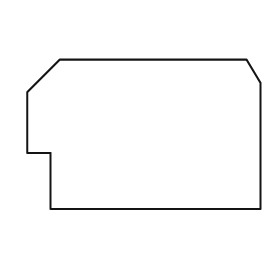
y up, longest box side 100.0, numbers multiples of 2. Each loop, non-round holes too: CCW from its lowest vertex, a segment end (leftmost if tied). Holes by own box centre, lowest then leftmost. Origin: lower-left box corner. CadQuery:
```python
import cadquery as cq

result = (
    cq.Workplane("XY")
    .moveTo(10.0, 0.0)
    .lineTo(100.0, 0.0)
    .lineTo(100.0, 54.0)
    .lineTo(94.0, 64.0)
    .lineTo(14.0, 64.0)
    .lineTo(0.0, 50.0)
    .lineTo(0.0, 24.0)
    .lineTo(10.0, 24.0)
    .close()
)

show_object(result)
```